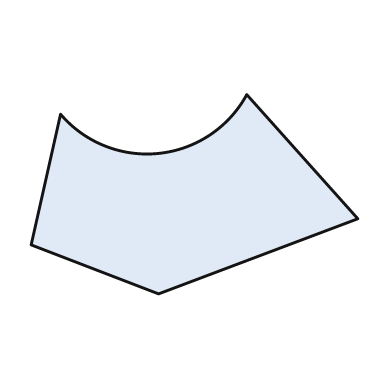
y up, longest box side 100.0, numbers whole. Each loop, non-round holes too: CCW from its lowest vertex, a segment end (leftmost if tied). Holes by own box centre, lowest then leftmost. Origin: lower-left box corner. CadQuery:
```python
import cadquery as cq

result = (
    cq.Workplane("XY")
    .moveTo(39.0, 0.0)
    .lineTo(100.0, 23.0)
    .lineTo(66.0, 61.0)
    .threePointArc((39.0, 43.0), (9.0, 55.0))
    .lineTo(0.0, 15.0)
    .close()
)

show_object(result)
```